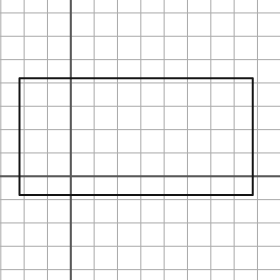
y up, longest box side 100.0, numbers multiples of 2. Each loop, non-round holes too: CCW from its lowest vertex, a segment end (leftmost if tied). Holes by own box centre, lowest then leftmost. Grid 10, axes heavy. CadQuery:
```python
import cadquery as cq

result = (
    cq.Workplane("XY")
    .moveTo(-22.0, -8.0)
    .lineTo(78.0, -8.0)
    .lineTo(78.0, 42.0)
    .lineTo(-22.0, 42.0)
    .close()
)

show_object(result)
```